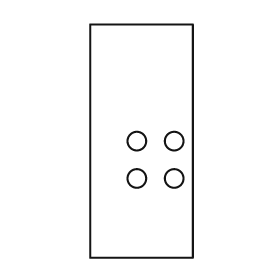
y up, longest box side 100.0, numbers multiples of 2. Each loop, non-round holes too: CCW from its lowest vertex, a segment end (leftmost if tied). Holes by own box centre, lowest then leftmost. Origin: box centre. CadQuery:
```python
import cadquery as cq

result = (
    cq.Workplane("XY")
    .moveTo(-22.0, -50.0)
    .lineTo(22.0, -50.0)
    .lineTo(22.0, 50.0)
    .lineTo(-22.0, 50.0)
    .close()
    .moveTo(-2.0, -16.0)
    .circle(4.0)
    .moveTo(14.0, -16.0)
    .circle(4.0)
    .moveTo(-2.0, 0.0)
    .circle(4.0)
    .moveTo(14.0, 0.0)
    .circle(4.0)
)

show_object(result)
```